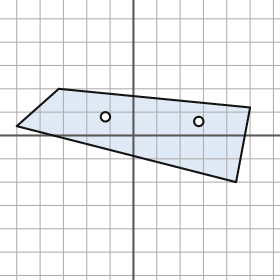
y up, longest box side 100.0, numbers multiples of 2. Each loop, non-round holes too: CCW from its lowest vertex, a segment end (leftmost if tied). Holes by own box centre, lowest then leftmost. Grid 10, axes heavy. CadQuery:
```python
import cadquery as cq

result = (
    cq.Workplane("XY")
    .moveTo(44.0, -20.0)
    .lineTo(50.0, 12.0)
    .lineTo(-32.0, 20.0)
    .lineTo(-50.0, 4.0)
    .close()
    .moveTo(28.0, 6.0)
    .circle(2.0)
    .moveTo(-12.0, 8.0)
    .circle(2.0)
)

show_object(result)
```